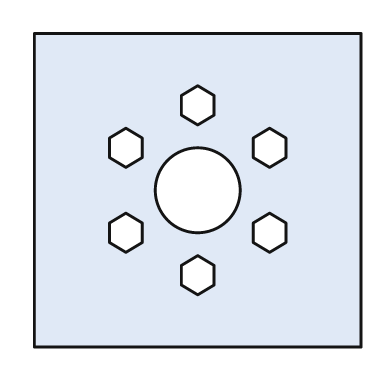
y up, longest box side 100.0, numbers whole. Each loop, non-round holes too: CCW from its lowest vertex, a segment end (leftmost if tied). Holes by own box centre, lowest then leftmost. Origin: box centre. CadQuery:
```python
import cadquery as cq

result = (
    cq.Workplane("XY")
    .moveTo(-50.0, -48.0)
    .lineTo(50.0, -48.0)
    .lineTo(50.0, 48.0)
    .lineTo(-50.0, 48.0)
    .close()
    .moveTo(0.0, -32.0)
    .lineTo(5.0, -29.0)
    .lineTo(5.0, -23.0)
    .lineTo(0.0, -20.0)
    .lineTo(-5.0, -23.0)
    .lineTo(-5.0, -29.0)
    .close()
    .moveTo(-22.0, -19.0)
    .lineTo(-17.0, -16.0)
    .lineTo(-17.0, -10.0)
    .lineTo(-22.0, -7.0)
    .lineTo(-27.0, -10.0)
    .lineTo(-27.0, -16.0)
    .close()
    .moveTo(22.0, -19.0)
    .lineTo(27.0, -16.0)
    .lineTo(27.0, -10.0)
    .lineTo(22.0, -7.0)
    .lineTo(17.0, -10.0)
    .lineTo(17.0, -16.0)
    .close()
    .moveTo(0.0, 0.0)
    .circle(13.0)
    .moveTo(-22.0, 7.0)
    .lineTo(-17.0, 10.0)
    .lineTo(-17.0, 16.0)
    .lineTo(-22.0, 19.0)
    .lineTo(-27.0, 16.0)
    .lineTo(-27.0, 10.0)
    .close()
    .moveTo(22.0, 7.0)
    .lineTo(27.0, 10.0)
    .lineTo(27.0, 16.0)
    .lineTo(22.0, 19.0)
    .lineTo(17.0, 16.0)
    .lineTo(17.0, 10.0)
    .close()
    .moveTo(0.0, 20.0)
    .lineTo(5.0, 23.0)
    .lineTo(5.0, 29.0)
    .lineTo(0.0, 32.0)
    .lineTo(-5.0, 29.0)
    .lineTo(-5.0, 23.0)
    .close()
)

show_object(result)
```